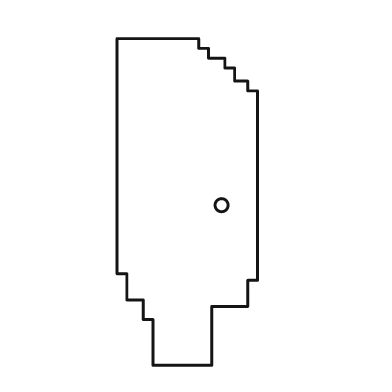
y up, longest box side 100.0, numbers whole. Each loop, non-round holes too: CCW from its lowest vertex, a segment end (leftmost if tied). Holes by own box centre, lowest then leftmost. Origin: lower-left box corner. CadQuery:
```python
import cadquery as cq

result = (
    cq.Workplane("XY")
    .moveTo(11.0, 0.0)
    .lineTo(29.0, 0.0)
    .lineTo(29.0, 18.0)
    .lineTo(40.0, 18.0)
    .lineTo(40.0, 26.0)
    .lineTo(43.0, 26.0)
    .lineTo(43.0, 84.0)
    .lineTo(40.0, 84.0)
    .lineTo(40.0, 87.0)
    .lineTo(36.0, 87.0)
    .lineTo(36.0, 91.0)
    .lineTo(33.0, 91.0)
    .lineTo(33.0, 94.0)
    .lineTo(28.0, 94.0)
    .lineTo(28.0, 97.0)
    .lineTo(25.0, 97.0)
    .lineTo(25.0, 100.0)
    .lineTo(0.0, 100.0)
    .lineTo(0.0, 28.0)
    .lineTo(3.0, 28.0)
    .lineTo(3.0, 20.0)
    .lineTo(8.0, 20.0)
    .lineTo(8.0, 14.0)
    .lineTo(11.0, 14.0)
    .close()
    .moveTo(32.0, 49.0)
    .circle(2.0)
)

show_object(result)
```